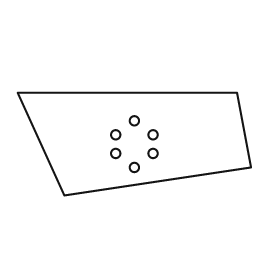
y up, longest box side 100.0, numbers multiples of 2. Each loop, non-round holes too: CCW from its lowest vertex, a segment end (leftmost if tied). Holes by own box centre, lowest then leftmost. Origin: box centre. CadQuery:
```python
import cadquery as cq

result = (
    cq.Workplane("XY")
    .moveTo(-30.0, -22.0)
    .lineTo(50.0, -10.0)
    .lineTo(44.0, 22.0)
    .lineTo(-50.0, 22.0)
    .close()
    .moveTo(0.0, -10.0)
    .circle(2.0)
    .moveTo(-8.0, -4.0)
    .circle(2.0)
    .moveTo(8.0, -4.0)
    .circle(2.0)
    .moveTo(-8.0, 4.0)
    .circle(2.0)
    .moveTo(8.0, 4.0)
    .circle(2.0)
    .moveTo(0.0, 10.0)
    .circle(2.0)
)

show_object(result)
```